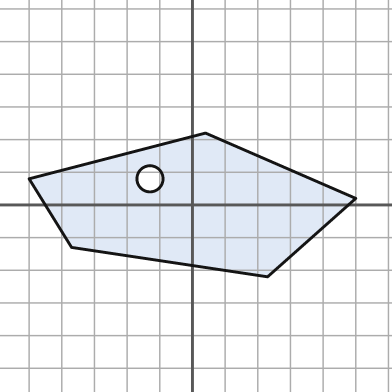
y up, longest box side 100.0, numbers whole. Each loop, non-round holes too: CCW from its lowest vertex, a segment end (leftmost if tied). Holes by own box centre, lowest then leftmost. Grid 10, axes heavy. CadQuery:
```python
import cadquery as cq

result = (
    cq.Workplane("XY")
    .moveTo(23.0, -22.0)
    .lineTo(50.0, 2.0)
    .lineTo(4.0, 22.0)
    .lineTo(-50.0, 8.0)
    .lineTo(-37.0, -13.0)
    .close()
    .moveTo(-13.0, 8.0)
    .circle(4.0)
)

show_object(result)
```